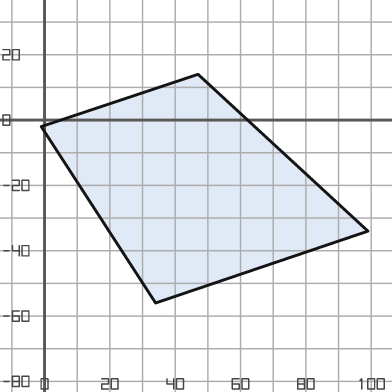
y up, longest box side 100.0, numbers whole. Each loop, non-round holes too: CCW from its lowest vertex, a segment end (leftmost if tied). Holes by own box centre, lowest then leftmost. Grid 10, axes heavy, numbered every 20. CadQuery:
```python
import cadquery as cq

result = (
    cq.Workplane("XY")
    .moveTo(34.0, -56.0)
    .lineTo(99.0, -34.0)
    .lineTo(47.0, 14.0)
    .lineTo(-1.0, -2.0)
    .close()
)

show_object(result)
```